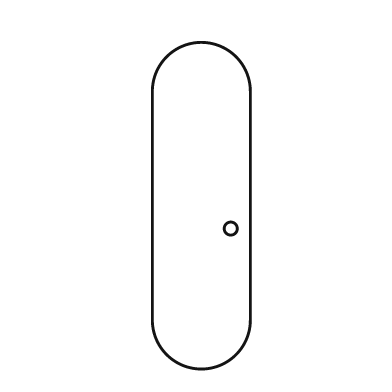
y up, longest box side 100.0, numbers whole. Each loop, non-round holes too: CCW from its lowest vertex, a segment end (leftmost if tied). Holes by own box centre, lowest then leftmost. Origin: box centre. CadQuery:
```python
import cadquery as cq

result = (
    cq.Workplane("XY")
    .moveTo(-15.0, -35.0)
    .threePointArc((0.0, -50.0), (15.0, -35.0))
    .lineTo(15.0, 35.0)
    .threePointArc((0.0, 50.0), (-15.0, 35.0))
    .close()
    .moveTo(9.0, -7.0)
    .circle(2.0)
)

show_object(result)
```